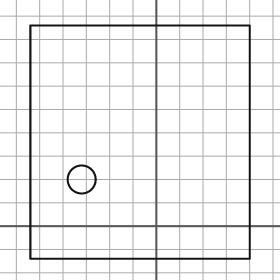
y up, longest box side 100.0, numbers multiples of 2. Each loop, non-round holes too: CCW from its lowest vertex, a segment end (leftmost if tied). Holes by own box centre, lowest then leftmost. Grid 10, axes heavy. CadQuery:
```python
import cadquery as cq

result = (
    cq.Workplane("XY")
    .moveTo(-54.0, -14.0)
    .lineTo(40.0, -14.0)
    .lineTo(40.0, 86.0)
    .lineTo(-54.0, 86.0)
    .close()
    .moveTo(-32.0, 20.0)
    .circle(6.0)
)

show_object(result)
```